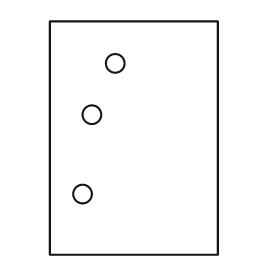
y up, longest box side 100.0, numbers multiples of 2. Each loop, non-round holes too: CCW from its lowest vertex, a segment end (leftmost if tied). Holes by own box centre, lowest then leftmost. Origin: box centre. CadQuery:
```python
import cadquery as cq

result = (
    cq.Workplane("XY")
    .moveTo(-36.0, -50.0)
    .lineTo(36.0, -50.0)
    .lineTo(36.0, 50.0)
    .lineTo(-36.0, 50.0)
    .close()
    .moveTo(-22.0, -24.0)
    .circle(4.0)
    .moveTo(-18.0, 10.0)
    .circle(4.0)
    .moveTo(-8.0, 32.0)
    .circle(4.0)
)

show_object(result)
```